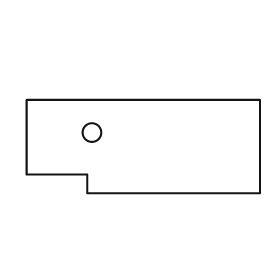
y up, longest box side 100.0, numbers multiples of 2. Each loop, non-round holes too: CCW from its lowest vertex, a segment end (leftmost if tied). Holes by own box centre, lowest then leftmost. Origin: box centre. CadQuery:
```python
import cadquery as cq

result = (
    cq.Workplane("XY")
    .moveTo(-24.0, -20.0)
    .lineTo(50.0, -20.0)
    .lineTo(50.0, 20.0)
    .lineTo(-50.0, 20.0)
    .lineTo(-50.0, -12.0)
    .lineTo(-24.0, -12.0)
    .close()
    .moveTo(-22.0, 6.0)
    .circle(4.0)
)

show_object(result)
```